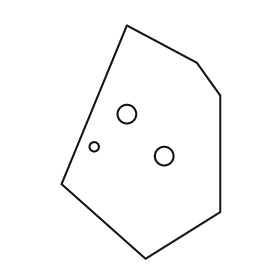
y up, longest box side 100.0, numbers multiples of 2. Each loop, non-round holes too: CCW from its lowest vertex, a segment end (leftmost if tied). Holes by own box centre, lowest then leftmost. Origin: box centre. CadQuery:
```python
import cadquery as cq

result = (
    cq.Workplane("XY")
    .moveTo(2.0, -50.0)
    .lineTo(34.0, -30.0)
    .lineTo(34.0, 20.0)
    .lineTo(24.0, 34.0)
    .lineTo(-6.0, 50.0)
    .lineTo(-34.0, -18.0)
    .close()
    .moveTo(10.0, -6.0)
    .circle(4.0)
    .moveTo(-20.0, -2.0)
    .circle(2.0)
    .moveTo(-6.0, 12.0)
    .circle(4.0)
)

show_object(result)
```